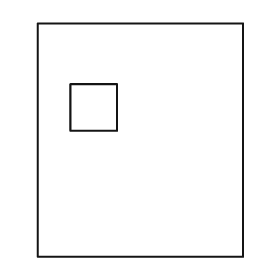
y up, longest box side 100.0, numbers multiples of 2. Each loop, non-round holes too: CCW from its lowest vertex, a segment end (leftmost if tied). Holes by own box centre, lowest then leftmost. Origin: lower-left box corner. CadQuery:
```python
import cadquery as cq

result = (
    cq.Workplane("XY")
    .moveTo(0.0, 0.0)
    .lineTo(88.0, 0.0)
    .lineTo(88.0, 100.0)
    .lineTo(0.0, 100.0)
    .close()
    .moveTo(14.0, 54.0)
    .lineTo(34.0, 54.0)
    .lineTo(34.0, 74.0)
    .lineTo(14.0, 74.0)
    .close()
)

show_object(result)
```